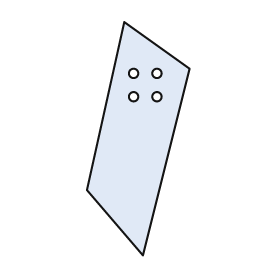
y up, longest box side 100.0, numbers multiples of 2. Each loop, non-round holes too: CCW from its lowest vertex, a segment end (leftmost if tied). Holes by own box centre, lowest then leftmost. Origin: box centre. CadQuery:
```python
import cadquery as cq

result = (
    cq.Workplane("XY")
    .moveTo(2.0, -50.0)
    .lineTo(22.0, 30.0)
    .lineTo(-6.0, 50.0)
    .lineTo(-22.0, -22.0)
    .close()
    .moveTo(-2.0, 18.0)
    .circle(2.0)
    .moveTo(8.0, 18.0)
    .circle(2.0)
    .moveTo(-2.0, 28.0)
    .circle(2.0)
    .moveTo(8.0, 28.0)
    .circle(2.0)
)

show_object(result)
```